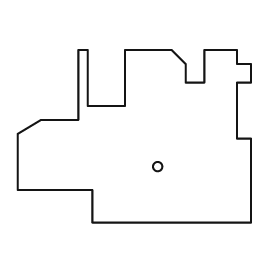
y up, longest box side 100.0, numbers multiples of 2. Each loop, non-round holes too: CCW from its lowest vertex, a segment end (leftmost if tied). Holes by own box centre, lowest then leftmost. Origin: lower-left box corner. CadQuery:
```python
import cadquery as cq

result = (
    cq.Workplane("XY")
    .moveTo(32.0, 0.0)
    .lineTo(100.0, 0.0)
    .lineTo(100.0, 36.0)
    .lineTo(94.0, 36.0)
    .lineTo(94.0, 60.0)
    .lineTo(100.0, 60.0)
    .lineTo(100.0, 68.0)
    .lineTo(94.0, 68.0)
    .lineTo(94.0, 74.0)
    .lineTo(80.0, 74.0)
    .lineTo(80.0, 60.0)
    .lineTo(72.0, 60.0)
    .lineTo(72.0, 68.0)
    .lineTo(66.0, 74.0)
    .lineTo(46.0, 74.0)
    .lineTo(46.0, 50.0)
    .lineTo(30.0, 50.0)
    .lineTo(30.0, 74.0)
    .lineTo(26.0, 74.0)
    .lineTo(26.0, 44.0)
    .lineTo(10.0, 44.0)
    .lineTo(0.0, 38.0)
    .lineTo(0.0, 14.0)
    .lineTo(32.0, 14.0)
    .close()
    .moveTo(60.0, 24.0)
    .circle(2.0)
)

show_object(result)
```